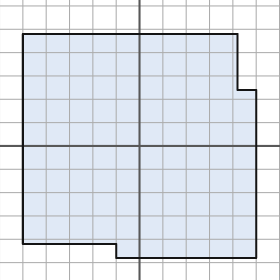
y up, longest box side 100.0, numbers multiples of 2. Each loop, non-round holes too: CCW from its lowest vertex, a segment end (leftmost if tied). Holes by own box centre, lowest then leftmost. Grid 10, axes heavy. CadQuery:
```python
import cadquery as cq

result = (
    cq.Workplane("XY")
    .moveTo(-10.0, -48.0)
    .lineTo(50.0, -48.0)
    .lineTo(50.0, 24.0)
    .lineTo(42.0, 24.0)
    .lineTo(42.0, 48.0)
    .lineTo(-50.0, 48.0)
    .lineTo(-50.0, -42.0)
    .lineTo(-10.0, -42.0)
    .close()
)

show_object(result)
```